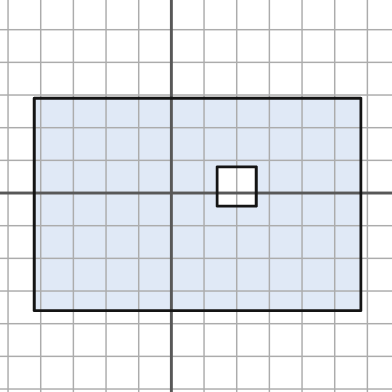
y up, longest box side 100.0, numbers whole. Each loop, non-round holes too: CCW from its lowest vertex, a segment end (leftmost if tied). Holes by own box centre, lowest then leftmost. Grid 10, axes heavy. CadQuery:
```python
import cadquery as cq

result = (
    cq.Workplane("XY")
    .moveTo(-42.0, -36.0)
    .lineTo(58.0, -36.0)
    .lineTo(58.0, 29.0)
    .lineTo(-42.0, 29.0)
    .close()
    .moveTo(14.0, -4.0)
    .lineTo(26.0, -4.0)
    .lineTo(26.0, 8.0)
    .lineTo(14.0, 8.0)
    .close()
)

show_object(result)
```